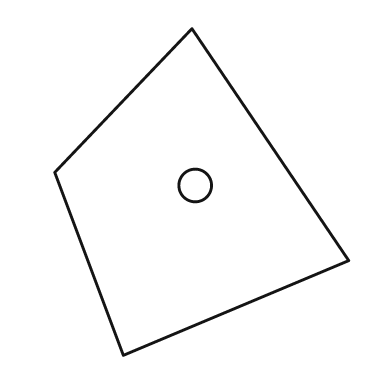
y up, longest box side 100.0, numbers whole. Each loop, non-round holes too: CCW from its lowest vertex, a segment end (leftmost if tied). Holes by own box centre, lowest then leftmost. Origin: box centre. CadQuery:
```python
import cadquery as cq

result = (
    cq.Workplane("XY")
    .moveTo(-24.0, -50.0)
    .lineTo(45.0, -21.0)
    .lineTo(-3.0, 50.0)
    .lineTo(-45.0, 6.0)
    .close()
    .moveTo(-2.0, 2.0)
    .circle(5.0)
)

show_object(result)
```